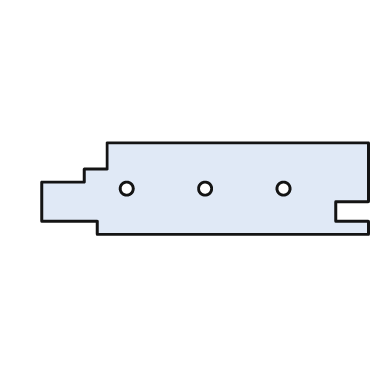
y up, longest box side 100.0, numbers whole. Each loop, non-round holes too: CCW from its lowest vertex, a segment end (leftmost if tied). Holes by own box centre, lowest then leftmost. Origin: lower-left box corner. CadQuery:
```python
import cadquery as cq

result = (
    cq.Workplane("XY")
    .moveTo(17.0, 0.0)
    .lineTo(100.0, 0.0)
    .lineTo(100.0, 4.0)
    .lineTo(90.0, 4.0)
    .lineTo(90.0, 10.0)
    .lineTo(100.0, 10.0)
    .lineTo(100.0, 28.0)
    .lineTo(20.0, 28.0)
    .lineTo(20.0, 20.0)
    .lineTo(13.0, 20.0)
    .lineTo(13.0, 16.0)
    .lineTo(0.0, 16.0)
    .lineTo(0.0, 4.0)
    .lineTo(17.0, 4.0)
    .close()
    .moveTo(26.0, 14.0)
    .circle(2.0)
    .moveTo(50.0, 14.0)
    .circle(2.0)
    .moveTo(74.0, 14.0)
    .circle(2.0)
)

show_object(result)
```